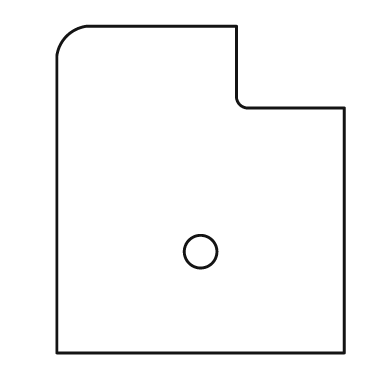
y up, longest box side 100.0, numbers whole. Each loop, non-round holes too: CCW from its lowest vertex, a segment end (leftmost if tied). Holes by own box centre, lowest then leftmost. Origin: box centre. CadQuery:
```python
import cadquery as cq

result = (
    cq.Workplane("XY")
    .moveTo(-44.0, -50.0)
    .lineTo(44.0, -50.0)
    .lineTo(44.0, 25.0)
    .lineTo(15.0, 25.0)
    .threePointArc((12.0, 26.0), (11.0, 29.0))
    .lineTo(11.0, 50.0)
    .lineTo(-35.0, 50.0)
    .threePointArc((-41.0, 47.0), (-44.0, 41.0))
    .close()
    .moveTo(0.0, -19.0)
    .circle(5.0)
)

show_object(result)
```